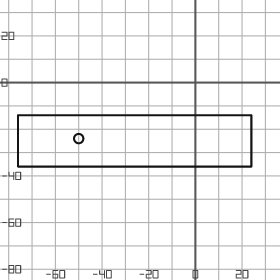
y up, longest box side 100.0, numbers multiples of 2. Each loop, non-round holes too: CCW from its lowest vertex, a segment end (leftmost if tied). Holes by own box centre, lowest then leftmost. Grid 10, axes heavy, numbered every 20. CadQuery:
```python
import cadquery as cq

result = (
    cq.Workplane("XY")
    .moveTo(-76.0, -36.0)
    .lineTo(24.0, -36.0)
    .lineTo(24.0, -14.0)
    .lineTo(-76.0, -14.0)
    .close()
    .moveTo(-50.0, -24.0)
    .circle(2.0)
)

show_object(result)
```